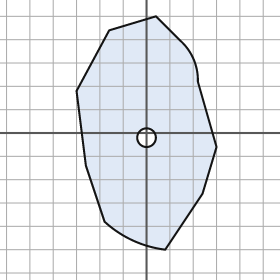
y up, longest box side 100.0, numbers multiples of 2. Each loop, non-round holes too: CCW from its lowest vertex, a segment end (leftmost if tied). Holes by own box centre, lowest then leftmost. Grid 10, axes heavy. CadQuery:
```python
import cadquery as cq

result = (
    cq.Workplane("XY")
    .moveTo(8.0, -50.0)
    .lineTo(24.0, -26.0)
    .lineTo(30.0, -6.0)
    .lineTo(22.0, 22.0)
    .threePointArc((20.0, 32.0), (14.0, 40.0))
    .lineTo(4.0, 50.0)
    .lineTo(-16.0, 44.0)
    .lineTo(-30.0, 18.0)
    .lineTo(-26.0, -14.0)
    .lineTo(-18.0, -38.0)
    .threePointArc((-6.0, -46.0), (8.0, -50.0))
    .close()
    .moveTo(0.0, -2.0)
    .circle(4.0)
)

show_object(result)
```